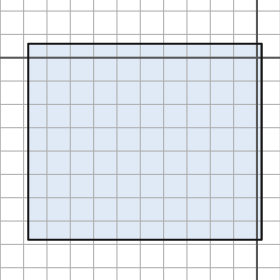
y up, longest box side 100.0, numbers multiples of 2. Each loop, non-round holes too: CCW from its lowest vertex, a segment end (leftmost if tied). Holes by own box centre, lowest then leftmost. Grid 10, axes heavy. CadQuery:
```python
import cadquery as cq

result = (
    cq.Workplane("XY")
    .moveTo(-98.0, -78.0)
    .lineTo(2.0, -78.0)
    .lineTo(2.0, 6.0)
    .lineTo(-98.0, 6.0)
    .close()
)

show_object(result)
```